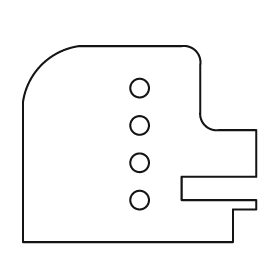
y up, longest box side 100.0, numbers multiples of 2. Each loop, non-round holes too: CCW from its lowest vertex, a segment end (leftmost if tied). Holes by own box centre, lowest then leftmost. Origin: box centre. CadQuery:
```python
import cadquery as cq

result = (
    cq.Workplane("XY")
    .moveTo(-50.0, -42.0)
    .lineTo(40.0, -42.0)
    .lineTo(40.0, -28.0)
    .lineTo(50.0, -28.0)
    .lineTo(50.0, -24.0)
    .lineTo(18.0, -24.0)
    .lineTo(18.0, -14.0)
    .lineTo(50.0, -14.0)
    .lineTo(50.0, 6.0)
    .lineTo(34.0, 6.0)
    .threePointArc((28.0, 8.0), (26.0, 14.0))
    .lineTo(26.0, 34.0)
    .threePointArc((24.0, 40.0), (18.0, 42.0))
    .lineTo(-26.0, 42.0)
    .threePointArc((-42.0, 34.0), (-50.0, 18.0))
    .close()
    .moveTo(0.0, -24.0)
    .circle(4.0)
    .moveTo(0.0, -8.0)
    .circle(4.0)
    .moveTo(0.0, 8.0)
    .circle(4.0)
    .moveTo(0.0, 24.0)
    .circle(4.0)
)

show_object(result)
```